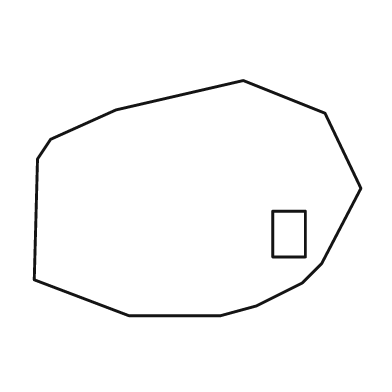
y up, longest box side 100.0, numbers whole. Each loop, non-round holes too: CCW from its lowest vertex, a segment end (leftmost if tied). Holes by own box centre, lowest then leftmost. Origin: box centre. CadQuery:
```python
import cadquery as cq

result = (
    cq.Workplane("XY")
    .moveTo(-21.0, -36.0)
    .lineTo(7.0, -36.0)
    .lineTo(18.0, -33.0)
    .lineTo(32.0, -26.0)
    .lineTo(38.0, -20.0)
    .lineTo(50.0, 3.0)
    .lineTo(39.0, 26.0)
    .lineTo(14.0, 36.0)
    .lineTo(-25.0, 27.0)
    .lineTo(-45.0, 18.0)
    .lineTo(-49.0, 12.0)
    .lineTo(-50.0, -25.0)
    .close()
    .moveTo(23.0, -18.0)
    .lineTo(33.0, -18.0)
    .lineTo(33.0, -4.0)
    .lineTo(23.0, -4.0)
    .close()
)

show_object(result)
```